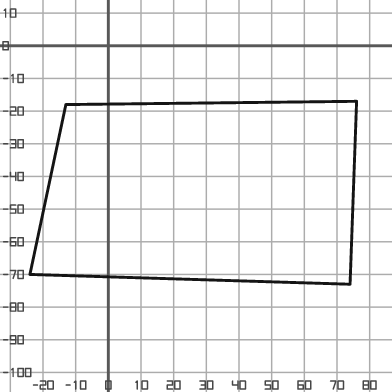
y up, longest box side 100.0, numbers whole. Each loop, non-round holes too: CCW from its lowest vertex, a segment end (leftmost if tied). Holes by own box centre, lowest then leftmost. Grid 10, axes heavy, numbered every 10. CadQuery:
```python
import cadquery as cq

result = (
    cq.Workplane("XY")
    .moveTo(74.0, -73.0)
    .lineTo(76.0, -17.0)
    .lineTo(-13.0, -18.0)
    .lineTo(-24.0, -70.0)
    .close()
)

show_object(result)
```